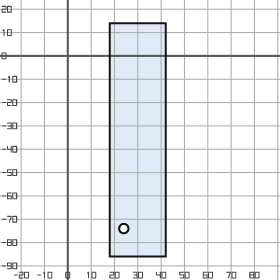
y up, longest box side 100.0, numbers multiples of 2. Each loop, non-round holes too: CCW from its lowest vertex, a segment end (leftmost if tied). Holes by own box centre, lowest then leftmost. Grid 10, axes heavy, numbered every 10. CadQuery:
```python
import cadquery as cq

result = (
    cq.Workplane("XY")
    .moveTo(18.0, -86.0)
    .lineTo(42.0, -86.0)
    .lineTo(42.0, 14.0)
    .lineTo(18.0, 14.0)
    .close()
    .moveTo(24.0, -74.0)
    .circle(2.0)
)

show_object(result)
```